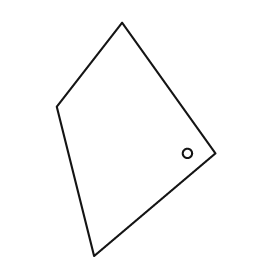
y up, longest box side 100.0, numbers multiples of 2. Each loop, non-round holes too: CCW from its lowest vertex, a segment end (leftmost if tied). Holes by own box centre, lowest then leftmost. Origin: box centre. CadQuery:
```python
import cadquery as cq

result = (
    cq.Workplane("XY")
    .moveTo(-18.0, -50.0)
    .lineTo(34.0, -6.0)
    .lineTo(-6.0, 50.0)
    .lineTo(-34.0, 14.0)
    .close()
    .moveTo(22.0, -6.0)
    .circle(2.0)
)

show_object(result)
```